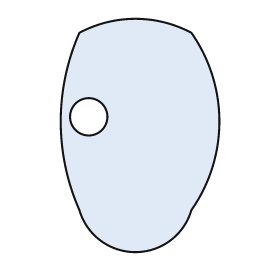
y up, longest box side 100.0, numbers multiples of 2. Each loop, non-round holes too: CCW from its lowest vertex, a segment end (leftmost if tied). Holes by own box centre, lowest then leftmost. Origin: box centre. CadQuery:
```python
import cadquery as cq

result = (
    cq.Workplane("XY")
    .moveTo(-26.0, -32.0)
    .threePointArc((-2.0, -50.0), (22.0, -32.0))
    .threePointArc((34.0, 6.0), (22.0, 44.0))
    .threePointArc((-2.0, 50.0), (-26.0, 44.0))
    .threePointArc((-34.0, 6.0), (-26.0, -32.0))
    .close()
    .moveTo(-22.0, 8.0)
    .circle(8.0)
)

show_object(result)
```